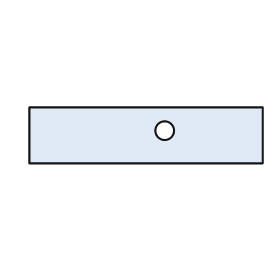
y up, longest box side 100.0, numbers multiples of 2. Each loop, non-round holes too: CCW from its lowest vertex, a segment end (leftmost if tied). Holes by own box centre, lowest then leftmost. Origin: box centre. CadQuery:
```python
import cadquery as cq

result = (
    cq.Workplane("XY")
    .moveTo(-50.0, -12.0)
    .lineTo(50.0, -12.0)
    .lineTo(50.0, 12.0)
    .lineTo(-50.0, 12.0)
    .close()
    .moveTo(8.0, 2.0)
    .circle(4.0)
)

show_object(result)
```